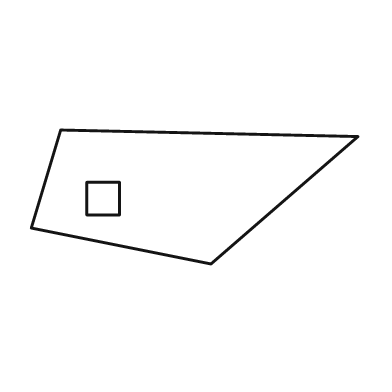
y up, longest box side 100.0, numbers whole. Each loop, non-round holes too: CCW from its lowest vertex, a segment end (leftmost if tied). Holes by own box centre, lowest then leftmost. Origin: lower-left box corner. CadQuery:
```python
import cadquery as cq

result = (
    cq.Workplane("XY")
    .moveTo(55.0, 0.0)
    .lineTo(100.0, 39.0)
    .lineTo(9.0, 41.0)
    .lineTo(0.0, 11.0)
    .close()
    .moveTo(17.0, 15.0)
    .lineTo(27.0, 15.0)
    .lineTo(27.0, 25.0)
    .lineTo(17.0, 25.0)
    .close()
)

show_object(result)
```